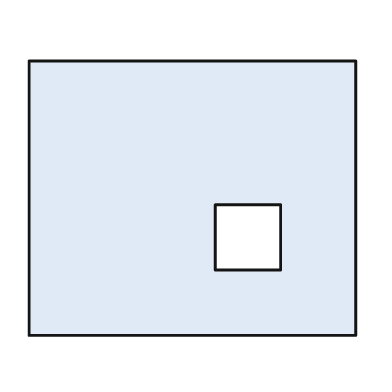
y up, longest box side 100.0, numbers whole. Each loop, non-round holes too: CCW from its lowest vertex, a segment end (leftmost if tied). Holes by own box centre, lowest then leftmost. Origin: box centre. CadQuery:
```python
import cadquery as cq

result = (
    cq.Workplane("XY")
    .moveTo(-50.0, -42.0)
    .lineTo(50.0, -42.0)
    .lineTo(50.0, 42.0)
    .lineTo(-50.0, 42.0)
    .close()
    .moveTo(7.0, -22.0)
    .lineTo(27.0, -22.0)
    .lineTo(27.0, -2.0)
    .lineTo(7.0, -2.0)
    .close()
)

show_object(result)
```